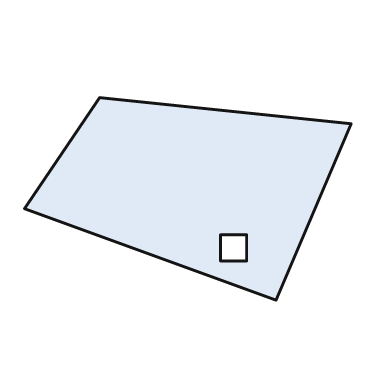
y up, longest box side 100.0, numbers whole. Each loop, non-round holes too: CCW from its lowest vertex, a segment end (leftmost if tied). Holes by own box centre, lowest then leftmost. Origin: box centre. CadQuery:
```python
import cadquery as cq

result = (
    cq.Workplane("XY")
    .moveTo(27.0, -31.0)
    .lineTo(50.0, 23.0)
    .lineTo(-27.0, 31.0)
    .lineTo(-50.0, -3.0)
    .close()
    .moveTo(10.0, -19.0)
    .lineTo(18.0, -19.0)
    .lineTo(18.0, -11.0)
    .lineTo(10.0, -11.0)
    .close()
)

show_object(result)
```